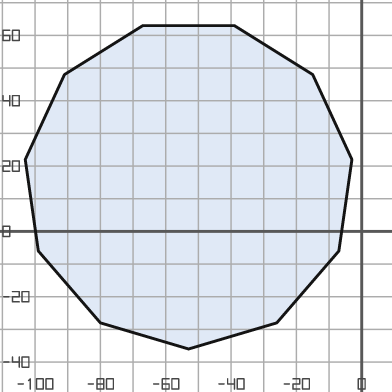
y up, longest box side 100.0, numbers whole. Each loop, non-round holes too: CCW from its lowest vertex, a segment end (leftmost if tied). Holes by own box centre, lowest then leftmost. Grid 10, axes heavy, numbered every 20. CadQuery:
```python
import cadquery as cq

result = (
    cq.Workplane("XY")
    .moveTo(-53.0, -36.0)
    .lineTo(-26.0, -28.0)
    .lineTo(-7.0, -6.0)
    .lineTo(-3.0, 22.0)
    .lineTo(-15.0, 48.0)
    .lineTo(-39.0, 63.0)
    .lineTo(-67.0, 63.0)
    .lineTo(-91.0, 48.0)
    .lineTo(-103.0, 22.0)
    .lineTo(-99.0, -6.0)
    .lineTo(-80.0, -28.0)
    .close()
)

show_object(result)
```